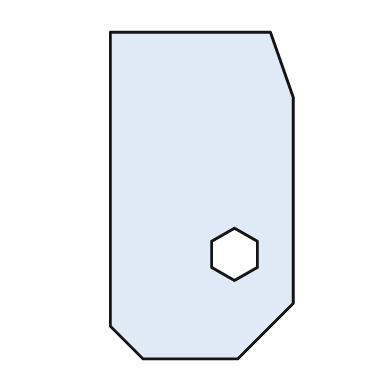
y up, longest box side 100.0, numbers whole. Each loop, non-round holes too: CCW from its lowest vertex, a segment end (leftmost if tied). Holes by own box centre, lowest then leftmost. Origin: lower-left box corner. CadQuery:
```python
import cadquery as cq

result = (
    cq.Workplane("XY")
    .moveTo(10.0, 0.0)
    .lineTo(39.0, 0.0)
    .lineTo(56.0, 17.0)
    .lineTo(56.0, 80.0)
    .lineTo(49.0, 100.0)
    .lineTo(0.0, 100.0)
    .lineTo(0.0, 10.0)
    .close()
    .moveTo(38.0, 24.0)
    .lineTo(45.0, 28.0)
    .lineTo(45.0, 36.0)
    .lineTo(38.0, 40.0)
    .lineTo(31.0, 36.0)
    .lineTo(31.0, 28.0)
    .close()
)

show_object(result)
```